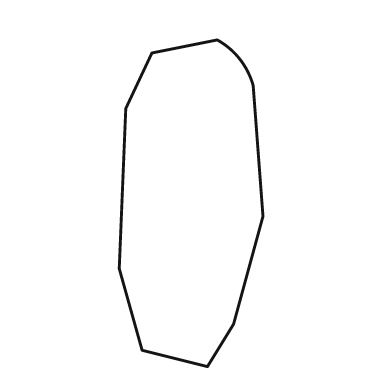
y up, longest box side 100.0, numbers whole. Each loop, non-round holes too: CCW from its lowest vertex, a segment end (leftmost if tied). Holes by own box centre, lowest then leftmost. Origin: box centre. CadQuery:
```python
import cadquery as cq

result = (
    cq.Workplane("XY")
    .moveTo(5.0, -50.0)
    .lineTo(13.0, -37.0)
    .lineTo(22.0, -4.0)
    .lineTo(19.0, 36.0)
    .threePointArc((15.0, 44.0), (8.0, 50.0))
    .lineTo(-12.0, 46.0)
    .lineTo(-20.0, 29.0)
    .lineTo(-22.0, -20.0)
    .lineTo(-15.0, -45.0)
    .close()
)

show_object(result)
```